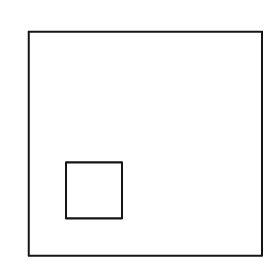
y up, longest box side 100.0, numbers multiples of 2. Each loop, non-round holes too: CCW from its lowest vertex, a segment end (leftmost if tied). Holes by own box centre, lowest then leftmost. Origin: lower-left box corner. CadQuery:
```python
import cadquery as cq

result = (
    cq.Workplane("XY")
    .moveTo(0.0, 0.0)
    .lineTo(100.0, 0.0)
    .lineTo(100.0, 96.0)
    .lineTo(0.0, 96.0)
    .close()
    .moveTo(16.0, 16.0)
    .lineTo(40.0, 16.0)
    .lineTo(40.0, 40.0)
    .lineTo(16.0, 40.0)
    .close()
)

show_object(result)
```